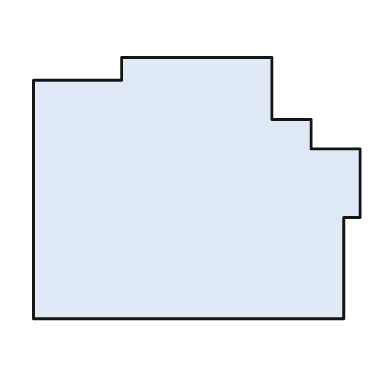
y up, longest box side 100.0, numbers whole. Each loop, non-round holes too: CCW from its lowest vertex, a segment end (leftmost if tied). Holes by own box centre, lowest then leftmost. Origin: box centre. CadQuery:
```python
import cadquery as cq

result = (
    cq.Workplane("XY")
    .moveTo(-50.0, -40.0)
    .lineTo(45.0, -40.0)
    .lineTo(45.0, -9.0)
    .lineTo(50.0, -9.0)
    .lineTo(50.0, 12.0)
    .lineTo(35.0, 12.0)
    .lineTo(35.0, 21.0)
    .lineTo(23.0, 21.0)
    .lineTo(23.0, 40.0)
    .lineTo(-23.0, 40.0)
    .lineTo(-23.0, 33.0)
    .lineTo(-50.0, 33.0)
    .close()
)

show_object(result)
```